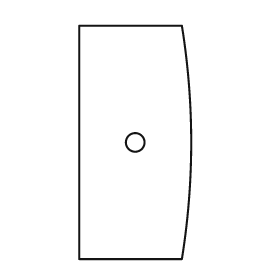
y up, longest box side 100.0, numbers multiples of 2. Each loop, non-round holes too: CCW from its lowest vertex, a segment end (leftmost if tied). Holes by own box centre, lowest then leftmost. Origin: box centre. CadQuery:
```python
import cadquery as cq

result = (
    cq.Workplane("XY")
    .moveTo(-24.0, -50.0)
    .lineTo(20.0, -50.0)
    .threePointArc((24.0, 0.0), (20.0, 50.0))
    .lineTo(-24.0, 50.0)
    .close()
    .moveTo(0.0, 0.0)
    .circle(4.0)
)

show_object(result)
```